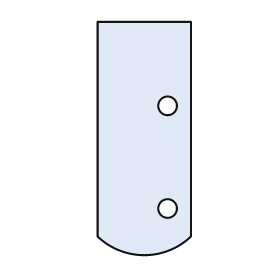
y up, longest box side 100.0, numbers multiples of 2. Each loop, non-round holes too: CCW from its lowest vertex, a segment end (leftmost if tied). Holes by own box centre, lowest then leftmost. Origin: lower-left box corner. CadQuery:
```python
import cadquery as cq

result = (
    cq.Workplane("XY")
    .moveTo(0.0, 8.0)
    .threePointArc((20.0, 0.0), (40.0, 8.0))
    .lineTo(40.0, 100.0)
    .lineTo(0.0, 100.0)
    .close()
    .moveTo(30.0, 20.0)
    .circle(4.0)
    .moveTo(30.0, 64.0)
    .circle(4.0)
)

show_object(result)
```